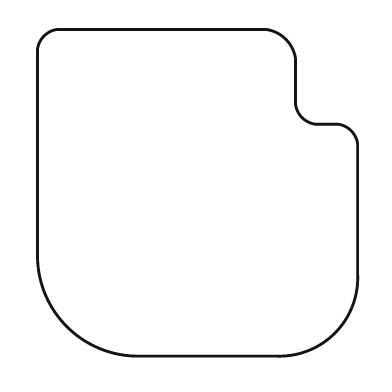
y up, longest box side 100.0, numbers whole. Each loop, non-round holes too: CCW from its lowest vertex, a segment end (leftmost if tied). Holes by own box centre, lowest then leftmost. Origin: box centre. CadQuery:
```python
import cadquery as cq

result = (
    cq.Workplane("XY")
    .moveTo(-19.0, -50.0)
    .lineTo(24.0, -50.0)
    .threePointArc((42.0, -43.0), (49.0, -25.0))
    .lineTo(49.0, 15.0)
    .threePointArc((47.0, 19.0), (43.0, 21.0))
    .lineTo(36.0, 21.0)
    .threePointArc((32.0, 23.0), (30.0, 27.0))
    .lineTo(30.0, 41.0)
    .threePointArc((27.0, 47.0), (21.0, 50.0))
    .lineTo(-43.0, 50.0)
    .threePointArc((-47.0, 48.0), (-49.0, 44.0))
    .lineTo(-49.0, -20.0)
    .threePointArc((-40.0, -41.0), (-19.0, -50.0))
    .close()
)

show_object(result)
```